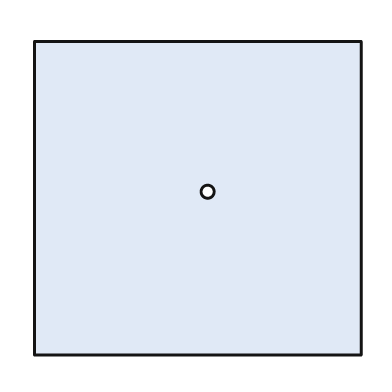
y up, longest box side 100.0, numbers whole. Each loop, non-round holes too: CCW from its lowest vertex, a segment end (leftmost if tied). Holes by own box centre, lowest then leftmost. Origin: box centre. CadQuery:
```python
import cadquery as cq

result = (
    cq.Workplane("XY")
    .moveTo(-50.0, -48.0)
    .lineTo(50.0, -48.0)
    .lineTo(50.0, 48.0)
    .lineTo(-50.0, 48.0)
    .close()
    .moveTo(3.0, 2.0)
    .circle(2.0)
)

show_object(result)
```